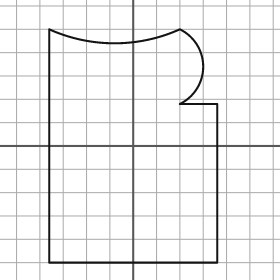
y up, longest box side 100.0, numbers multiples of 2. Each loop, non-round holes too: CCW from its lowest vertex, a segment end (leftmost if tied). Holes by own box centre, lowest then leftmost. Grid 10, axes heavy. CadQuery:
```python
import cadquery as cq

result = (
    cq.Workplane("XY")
    .moveTo(-36.0, -50.0)
    .lineTo(36.0, -50.0)
    .lineTo(36.0, 18.0)
    .lineTo(20.0, 18.0)
    .threePointArc((30.0, 34.0), (20.0, 50.0))
    .threePointArc((-8.0, 44.0), (-36.0, 50.0))
    .close()
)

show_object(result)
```